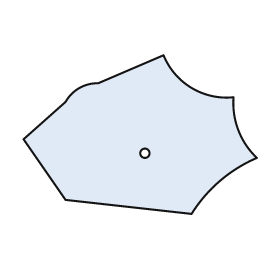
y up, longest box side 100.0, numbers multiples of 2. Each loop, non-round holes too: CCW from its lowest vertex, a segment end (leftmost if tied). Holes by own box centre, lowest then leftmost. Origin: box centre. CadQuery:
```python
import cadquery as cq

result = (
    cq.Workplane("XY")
    .moveTo(22.0, -34.0)
    .threePointArc((34.0, -20.0), (50.0, -10.0))
    .threePointArc((42.0, 2.0), (40.0, 16.0))
    .threePointArc((22.0, 20.0), (10.0, 34.0))
    .lineTo(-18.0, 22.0)
    .threePointArc((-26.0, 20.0), (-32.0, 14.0))
    .lineTo(-50.0, -2.0)
    .lineTo(-32.0, -28.0)
    .close()
    .moveTo(2.0, -8.0)
    .circle(2.0)
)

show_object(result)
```